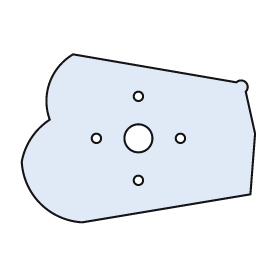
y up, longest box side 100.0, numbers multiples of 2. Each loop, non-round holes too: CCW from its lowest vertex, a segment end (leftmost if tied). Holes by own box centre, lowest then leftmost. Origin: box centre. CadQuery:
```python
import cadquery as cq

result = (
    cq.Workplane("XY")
    .moveTo(-24.0, -36.0)
    .lineTo(48.0, -24.0)
    .lineTo(50.0, 2.0)
    .lineTo(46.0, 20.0)
    .threePointArc((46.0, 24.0), (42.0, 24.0))
    .lineTo(-28.0, 36.0)
    .threePointArc((-38.0, 24.0), (-38.0, 8.0))
    .threePointArc((-46.0, 0.0), (-50.0, -10.0))
    .threePointArc((-42.0, -28.0), (-24.0, -36.0))
    .close()
    .moveTo(0.0, -18.0)
    .circle(2.0)
    .moveTo(-18.0, 0.0)
    .circle(2.0)
    .moveTo(0.0, 0.0)
    .circle(6.0)
    .moveTo(18.0, 0.0)
    .circle(2.0)
    .moveTo(0.0, 18.0)
    .circle(2.0)
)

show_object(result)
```